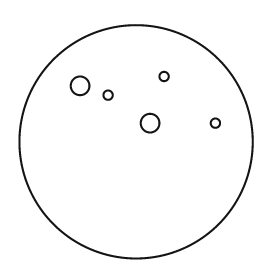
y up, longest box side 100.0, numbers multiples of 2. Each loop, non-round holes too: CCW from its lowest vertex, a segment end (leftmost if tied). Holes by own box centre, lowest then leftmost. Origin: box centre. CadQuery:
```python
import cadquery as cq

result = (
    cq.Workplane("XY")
    .moveTo(0.0, 0.0)
    .circle(50.0)
    .moveTo(6.0, 8.0)
    .circle(4.0)
    .moveTo(34.0, 8.0)
    .circle(2.0)
    .moveTo(-12.0, 20.0)
    .circle(2.0)
    .moveTo(-24.0, 24.0)
    .circle(4.0)
    .moveTo(12.0, 28.0)
    .circle(2.0)
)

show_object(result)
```